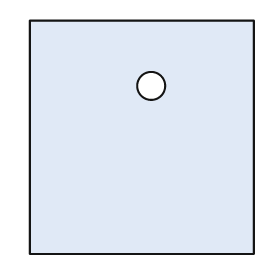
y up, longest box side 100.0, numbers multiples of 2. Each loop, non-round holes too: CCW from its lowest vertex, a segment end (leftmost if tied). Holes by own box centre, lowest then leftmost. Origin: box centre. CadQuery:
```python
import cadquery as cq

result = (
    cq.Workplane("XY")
    .moveTo(-48.0, -50.0)
    .lineTo(48.0, -50.0)
    .lineTo(48.0, 50.0)
    .lineTo(-48.0, 50.0)
    .close()
    .moveTo(4.0, 22.0)
    .circle(6.0)
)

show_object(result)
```